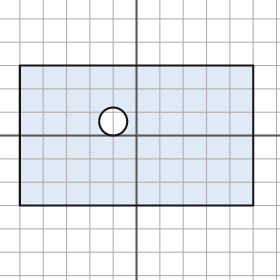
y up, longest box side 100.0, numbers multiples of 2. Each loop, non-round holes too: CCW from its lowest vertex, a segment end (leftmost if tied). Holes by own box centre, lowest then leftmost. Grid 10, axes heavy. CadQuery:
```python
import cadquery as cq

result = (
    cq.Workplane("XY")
    .moveTo(-50.0, -30.0)
    .lineTo(50.0, -30.0)
    .lineTo(50.0, 30.0)
    .lineTo(-50.0, 30.0)
    .close()
    .moveTo(-10.0, 6.0)
    .circle(6.0)
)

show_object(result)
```